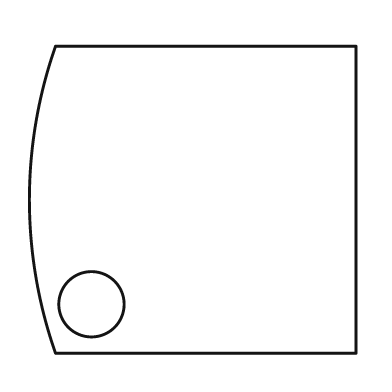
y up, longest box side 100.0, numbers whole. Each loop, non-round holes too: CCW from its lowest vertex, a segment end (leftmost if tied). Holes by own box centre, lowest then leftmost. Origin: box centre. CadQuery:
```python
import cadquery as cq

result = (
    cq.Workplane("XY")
    .moveTo(-42.0, -47.0)
    .lineTo(50.0, -47.0)
    .lineTo(50.0, 47.0)
    .lineTo(-42.0, 47.0)
    .threePointArc((-50.0, 0.0), (-42.0, -47.0))
    .close()
    .moveTo(-31.0, -32.0)
    .circle(10.0)
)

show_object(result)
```